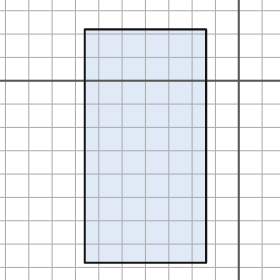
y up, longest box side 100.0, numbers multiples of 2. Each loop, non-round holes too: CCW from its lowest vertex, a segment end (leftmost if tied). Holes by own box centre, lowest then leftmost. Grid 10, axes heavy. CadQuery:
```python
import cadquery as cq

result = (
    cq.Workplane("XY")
    .moveTo(-66.0, -78.0)
    .lineTo(-14.0, -78.0)
    .lineTo(-14.0, 22.0)
    .lineTo(-66.0, 22.0)
    .close()
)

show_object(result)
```